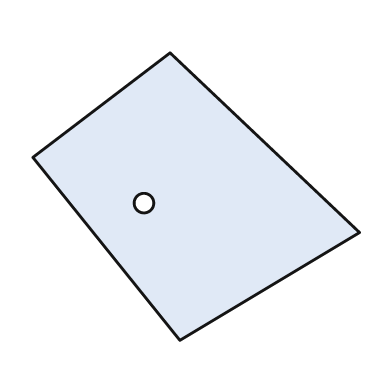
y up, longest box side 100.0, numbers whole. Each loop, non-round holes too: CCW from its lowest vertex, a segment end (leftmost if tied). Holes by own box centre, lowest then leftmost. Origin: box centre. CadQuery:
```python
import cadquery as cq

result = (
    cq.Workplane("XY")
    .moveTo(-5.0, -44.0)
    .lineTo(50.0, -11.0)
    .lineTo(-8.0, 44.0)
    .lineTo(-50.0, 12.0)
    .close()
    .moveTo(-16.0, -2.0)
    .circle(3.0)
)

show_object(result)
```